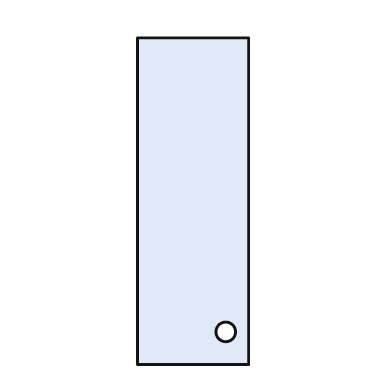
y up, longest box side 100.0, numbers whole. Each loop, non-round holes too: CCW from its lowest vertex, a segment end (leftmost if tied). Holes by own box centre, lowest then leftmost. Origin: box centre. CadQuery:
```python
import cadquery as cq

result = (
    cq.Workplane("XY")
    .moveTo(-17.0, -50.0)
    .lineTo(17.0, -50.0)
    .lineTo(17.0, 50.0)
    .lineTo(-17.0, 50.0)
    .close()
    .moveTo(10.0, -40.0)
    .circle(3.0)
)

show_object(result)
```